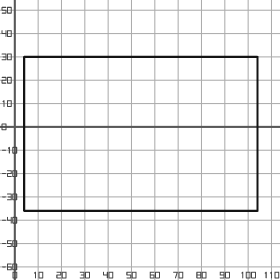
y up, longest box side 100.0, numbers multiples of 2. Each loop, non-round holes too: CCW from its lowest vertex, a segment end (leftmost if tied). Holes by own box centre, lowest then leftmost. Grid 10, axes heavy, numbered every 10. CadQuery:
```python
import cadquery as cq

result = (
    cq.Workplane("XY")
    .moveTo(4.0, -36.0)
    .lineTo(104.0, -36.0)
    .lineTo(104.0, 30.0)
    .lineTo(4.0, 30.0)
    .close()
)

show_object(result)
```